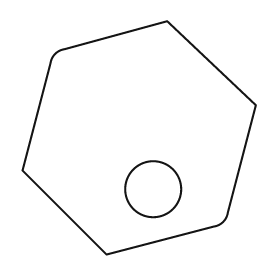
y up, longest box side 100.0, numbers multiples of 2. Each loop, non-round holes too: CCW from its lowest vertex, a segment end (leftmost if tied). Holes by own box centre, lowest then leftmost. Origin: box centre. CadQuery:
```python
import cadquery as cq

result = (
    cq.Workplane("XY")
    .moveTo(-14.0, -50.0)
    .lineTo(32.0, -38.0)
    .threePointArc((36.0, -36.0), (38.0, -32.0))
    .lineTo(50.0, 14.0)
    .lineTo(12.0, 50.0)
    .lineTo(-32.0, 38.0)
    .threePointArc((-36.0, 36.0), (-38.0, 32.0))
    .lineTo(-50.0, -14.0)
    .close()
    .moveTo(6.0, -22.0)
    .circle(12.0)
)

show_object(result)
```